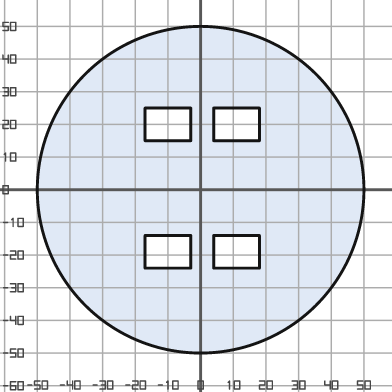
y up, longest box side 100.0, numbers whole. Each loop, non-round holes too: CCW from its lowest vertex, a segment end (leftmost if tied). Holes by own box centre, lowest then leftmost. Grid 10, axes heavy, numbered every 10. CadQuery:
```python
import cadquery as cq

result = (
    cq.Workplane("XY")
    .moveTo(0.0, 0.0)
    .circle(50.0)
    .moveTo(-17.0, -24.0)
    .lineTo(-3.0, -24.0)
    .lineTo(-3.0, -14.0)
    .lineTo(-17.0, -14.0)
    .close()
    .moveTo(4.0, -24.0)
    .lineTo(18.0, -24.0)
    .lineTo(18.0, -14.0)
    .lineTo(4.0, -14.0)
    .close()
    .moveTo(-17.0, 15.0)
    .lineTo(-3.0, 15.0)
    .lineTo(-3.0, 25.0)
    .lineTo(-17.0, 25.0)
    .close()
    .moveTo(4.0, 15.0)
    .lineTo(18.0, 15.0)
    .lineTo(18.0, 25.0)
    .lineTo(4.0, 25.0)
    .close()
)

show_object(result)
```